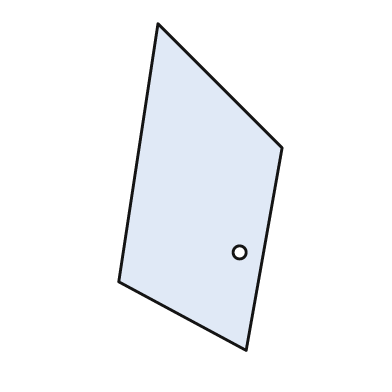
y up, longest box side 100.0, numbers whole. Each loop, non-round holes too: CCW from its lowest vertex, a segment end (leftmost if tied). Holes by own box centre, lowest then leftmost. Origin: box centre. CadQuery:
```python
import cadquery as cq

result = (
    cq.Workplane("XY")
    .moveTo(14.0, -50.0)
    .lineTo(25.0, 12.0)
    .lineTo(-13.0, 50.0)
    .lineTo(-25.0, -29.0)
    .close()
    .moveTo(12.0, -20.0)
    .circle(2.0)
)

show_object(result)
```